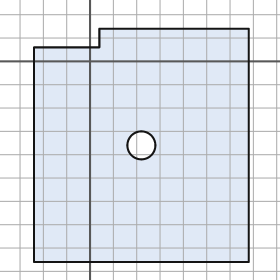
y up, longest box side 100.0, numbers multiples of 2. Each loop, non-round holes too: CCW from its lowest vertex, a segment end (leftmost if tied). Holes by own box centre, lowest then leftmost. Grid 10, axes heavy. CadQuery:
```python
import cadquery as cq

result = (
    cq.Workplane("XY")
    .moveTo(-24.0, -86.0)
    .lineTo(68.0, -86.0)
    .lineTo(68.0, 14.0)
    .lineTo(4.0, 14.0)
    .lineTo(4.0, 6.0)
    .lineTo(-24.0, 6.0)
    .close()
    .moveTo(22.0, -36.0)
    .circle(6.0)
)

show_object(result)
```